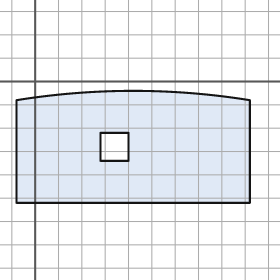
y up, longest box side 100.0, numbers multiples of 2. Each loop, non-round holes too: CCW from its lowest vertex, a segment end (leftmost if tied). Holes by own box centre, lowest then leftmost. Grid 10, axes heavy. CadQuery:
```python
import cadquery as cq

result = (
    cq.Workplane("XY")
    .moveTo(-8.0, -52.0)
    .lineTo(92.0, -52.0)
    .lineTo(92.0, -8.0)
    .threePointArc((42.0, -4.0), (-8.0, -8.0))
    .close()
    .moveTo(28.0, -34.0)
    .lineTo(40.0, -34.0)
    .lineTo(40.0, -22.0)
    .lineTo(28.0, -22.0)
    .close()
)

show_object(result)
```